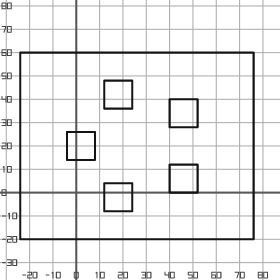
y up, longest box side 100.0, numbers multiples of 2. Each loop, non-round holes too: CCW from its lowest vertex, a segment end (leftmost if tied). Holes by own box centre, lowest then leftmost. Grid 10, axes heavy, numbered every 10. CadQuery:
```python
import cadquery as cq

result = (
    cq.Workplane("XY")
    .moveTo(-24.0, -20.0)
    .lineTo(76.0, -20.0)
    .lineTo(76.0, 60.0)
    .lineTo(-24.0, 60.0)
    .close()
    .moveTo(12.0, -8.0)
    .lineTo(24.0, -8.0)
    .lineTo(24.0, 4.0)
    .lineTo(12.0, 4.0)
    .close()
    .moveTo(40.0, 0.0)
    .lineTo(52.0, 0.0)
    .lineTo(52.0, 12.0)
    .lineTo(40.0, 12.0)
    .close()
    .moveTo(-4.0, 14.0)
    .lineTo(8.0, 14.0)
    .lineTo(8.0, 26.0)
    .lineTo(-4.0, 26.0)
    .close()
    .moveTo(40.0, 28.0)
    .lineTo(52.0, 28.0)
    .lineTo(52.0, 40.0)
    .lineTo(40.0, 40.0)
    .close()
    .moveTo(12.0, 36.0)
    .lineTo(24.0, 36.0)
    .lineTo(24.0, 48.0)
    .lineTo(12.0, 48.0)
    .close()
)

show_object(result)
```